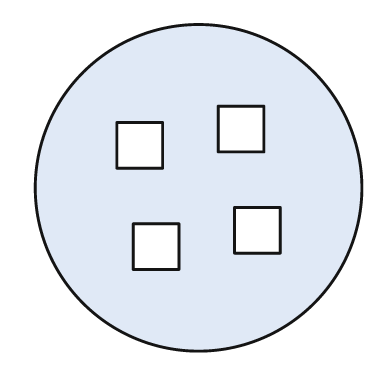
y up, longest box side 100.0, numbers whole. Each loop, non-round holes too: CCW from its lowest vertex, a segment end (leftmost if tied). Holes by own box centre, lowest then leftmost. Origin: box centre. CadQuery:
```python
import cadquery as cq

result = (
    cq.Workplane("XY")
    .moveTo(0.0, 0.0)
    .circle(50.0)
    .moveTo(-20.0, -25.0)
    .lineTo(-6.0, -25.0)
    .lineTo(-6.0, -11.0)
    .lineTo(-20.0, -11.0)
    .close()
    .moveTo(11.0, -20.0)
    .lineTo(25.0, -20.0)
    .lineTo(25.0, -6.0)
    .lineTo(11.0, -6.0)
    .close()
    .moveTo(-25.0, 6.0)
    .lineTo(-11.0, 6.0)
    .lineTo(-11.0, 20.0)
    .lineTo(-25.0, 20.0)
    .close()
    .moveTo(6.0, 11.0)
    .lineTo(20.0, 11.0)
    .lineTo(20.0, 25.0)
    .lineTo(6.0, 25.0)
    .close()
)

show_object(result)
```